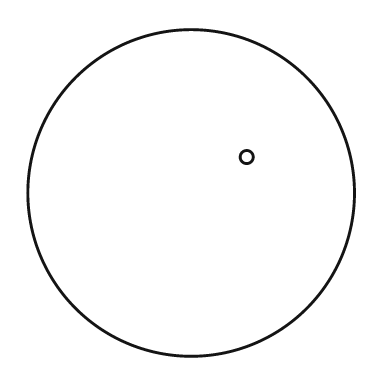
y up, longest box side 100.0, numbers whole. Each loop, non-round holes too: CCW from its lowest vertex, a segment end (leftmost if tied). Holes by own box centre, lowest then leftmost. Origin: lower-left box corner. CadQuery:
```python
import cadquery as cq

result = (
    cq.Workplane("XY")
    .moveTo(50.0, 50.0)
    .circle(50.0)
    .moveTo(67.0, 61.0)
    .circle(2.0)
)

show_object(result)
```